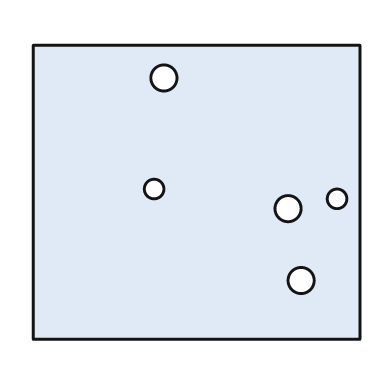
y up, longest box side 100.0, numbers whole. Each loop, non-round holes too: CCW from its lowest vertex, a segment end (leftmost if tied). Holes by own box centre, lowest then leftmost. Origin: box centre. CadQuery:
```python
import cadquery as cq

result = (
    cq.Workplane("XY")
    .moveTo(-50.0, -45.0)
    .lineTo(50.0, -45.0)
    .lineTo(50.0, 45.0)
    .lineTo(-50.0, 45.0)
    .close()
    .moveTo(32.0, -27.0)
    .circle(4.0)
    .moveTo(28.0, -5.0)
    .circle(4.0)
    .moveTo(43.0, -2.0)
    .circle(3.0)
    .moveTo(-13.0, 1.0)
    .circle(3.0)
    .moveTo(-10.0, 35.0)
    .circle(4.0)
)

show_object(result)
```